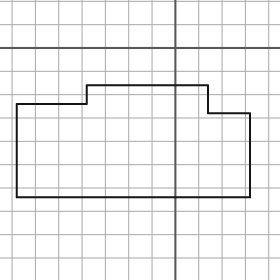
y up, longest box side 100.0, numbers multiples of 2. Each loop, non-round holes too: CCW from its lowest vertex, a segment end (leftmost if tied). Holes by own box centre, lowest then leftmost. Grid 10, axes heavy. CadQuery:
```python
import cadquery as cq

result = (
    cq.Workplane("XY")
    .moveTo(-68.0, -64.0)
    .lineTo(32.0, -64.0)
    .lineTo(32.0, -28.0)
    .lineTo(14.0, -28.0)
    .lineTo(14.0, -16.0)
    .lineTo(-38.0, -16.0)
    .lineTo(-38.0, -24.0)
    .lineTo(-68.0, -24.0)
    .close()
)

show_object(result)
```